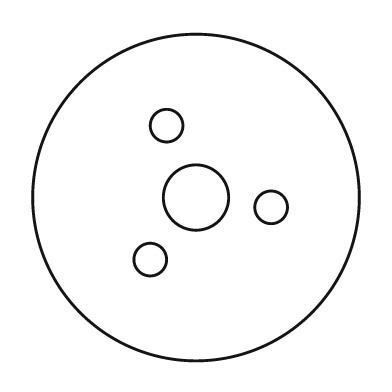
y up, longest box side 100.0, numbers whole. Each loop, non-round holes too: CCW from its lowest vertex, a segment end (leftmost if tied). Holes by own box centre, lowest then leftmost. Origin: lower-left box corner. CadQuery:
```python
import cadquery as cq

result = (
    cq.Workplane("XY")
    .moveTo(50.0, 50.0)
    .circle(50.0)
    .moveTo(36.0, 31.0)
    .circle(5.0)
    .moveTo(73.0, 47.0)
    .circle(5.0)
    .moveTo(50.0, 50.0)
    .circle(10.0)
    .moveTo(41.0, 72.0)
    .circle(5.0)
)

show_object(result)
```